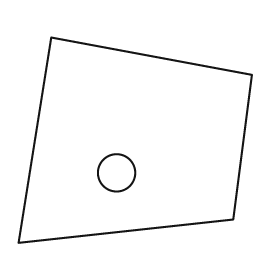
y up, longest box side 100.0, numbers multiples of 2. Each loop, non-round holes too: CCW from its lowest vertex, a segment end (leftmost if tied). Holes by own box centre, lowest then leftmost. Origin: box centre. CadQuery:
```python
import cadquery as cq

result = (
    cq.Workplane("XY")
    .moveTo(-50.0, -44.0)
    .lineTo(42.0, -34.0)
    .lineTo(50.0, 28.0)
    .lineTo(-36.0, 44.0)
    .close()
    .moveTo(-8.0, -14.0)
    .circle(8.0)
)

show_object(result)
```